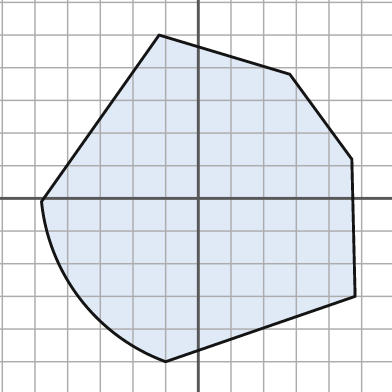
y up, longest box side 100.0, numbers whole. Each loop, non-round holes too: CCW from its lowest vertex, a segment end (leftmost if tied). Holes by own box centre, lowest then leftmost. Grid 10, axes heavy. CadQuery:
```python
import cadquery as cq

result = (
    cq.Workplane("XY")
    .moveTo(-10.0, -50.0)
    .lineTo(48.0, -30.0)
    .lineTo(47.0, 12.0)
    .lineTo(28.0, 38.0)
    .lineTo(-12.0, 50.0)
    .lineTo(-48.0, -1.0)
    .threePointArc((-36.0, -31.0), (-10.0, -50.0))
    .close()
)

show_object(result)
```